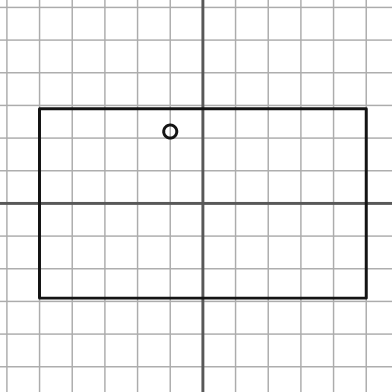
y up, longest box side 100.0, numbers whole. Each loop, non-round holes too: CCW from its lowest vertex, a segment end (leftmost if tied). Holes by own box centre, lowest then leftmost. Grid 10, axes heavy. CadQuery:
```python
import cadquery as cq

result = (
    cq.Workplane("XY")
    .moveTo(-50.0, -29.0)
    .lineTo(50.0, -29.0)
    .lineTo(50.0, 29.0)
    .lineTo(-50.0, 29.0)
    .close()
    .moveTo(-10.0, 22.0)
    .circle(2.0)
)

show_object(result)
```